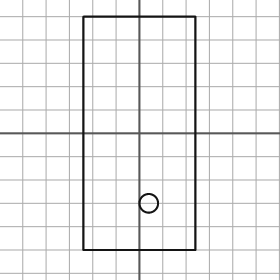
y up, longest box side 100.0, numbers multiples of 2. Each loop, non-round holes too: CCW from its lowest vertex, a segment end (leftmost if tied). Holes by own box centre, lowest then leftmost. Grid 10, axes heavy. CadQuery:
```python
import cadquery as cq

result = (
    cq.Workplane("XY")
    .moveTo(-24.0, -50.0)
    .lineTo(24.0, -50.0)
    .lineTo(24.0, 50.0)
    .lineTo(-24.0, 50.0)
    .close()
    .moveTo(4.0, -30.0)
    .circle(4.0)
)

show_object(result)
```